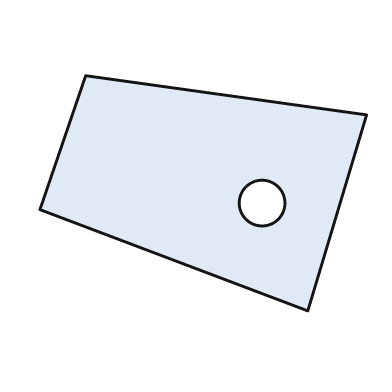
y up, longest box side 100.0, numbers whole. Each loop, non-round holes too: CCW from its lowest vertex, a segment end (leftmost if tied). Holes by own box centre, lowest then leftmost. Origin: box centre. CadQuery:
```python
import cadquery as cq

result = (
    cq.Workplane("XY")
    .moveTo(32.0, -36.0)
    .lineTo(50.0, 24.0)
    .lineTo(-36.0, 36.0)
    .lineTo(-50.0, -5.0)
    .close()
    .moveTo(18.0, -3.0)
    .circle(7.0)
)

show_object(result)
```